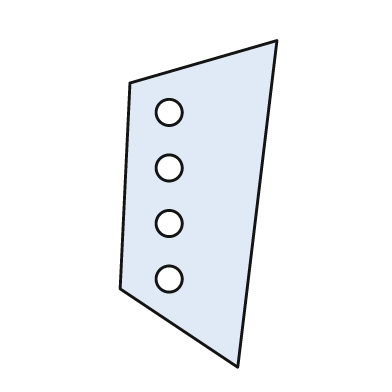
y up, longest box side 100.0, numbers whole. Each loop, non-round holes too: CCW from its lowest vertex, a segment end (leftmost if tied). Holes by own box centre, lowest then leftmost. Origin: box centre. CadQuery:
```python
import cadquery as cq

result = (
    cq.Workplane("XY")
    .moveTo(12.0, -50.0)
    .lineTo(24.0, 50.0)
    .lineTo(-21.0, 37.0)
    .lineTo(-24.0, -26.0)
    .close()
    .moveTo(-9.0, -23.0)
    .circle(4.0)
    .moveTo(-9.0, -6.0)
    .circle(4.0)
    .moveTo(-9.0, 11.0)
    .circle(4.0)
    .moveTo(-9.0, 28.0)
    .circle(4.0)
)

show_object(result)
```